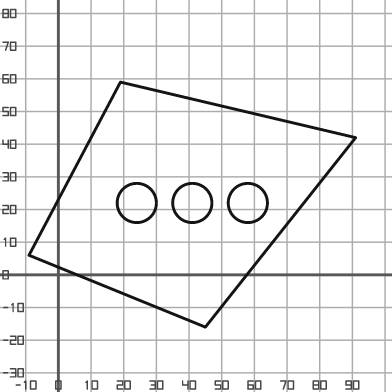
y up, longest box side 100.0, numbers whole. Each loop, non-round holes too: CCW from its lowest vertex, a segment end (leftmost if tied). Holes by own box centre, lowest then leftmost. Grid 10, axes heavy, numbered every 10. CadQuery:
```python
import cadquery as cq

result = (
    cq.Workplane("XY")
    .moveTo(45.0, -16.0)
    .lineTo(91.0, 42.0)
    .lineTo(19.0, 59.0)
    .lineTo(-9.0, 6.0)
    .close()
    .moveTo(24.0, 22.0)
    .circle(6.0)
    .moveTo(41.0, 22.0)
    .circle(6.0)
    .moveTo(58.0, 22.0)
    .circle(6.0)
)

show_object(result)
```